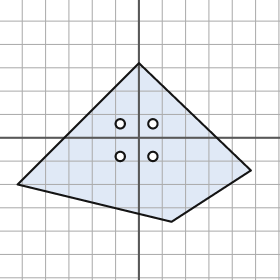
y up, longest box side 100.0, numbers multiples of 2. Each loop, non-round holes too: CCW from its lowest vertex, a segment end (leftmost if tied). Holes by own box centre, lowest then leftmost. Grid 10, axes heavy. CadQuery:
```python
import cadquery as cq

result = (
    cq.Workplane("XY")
    .moveTo(14.0, -36.0)
    .lineTo(48.0, -14.0)
    .lineTo(0.0, 32.0)
    .lineTo(-52.0, -20.0)
    .close()
    .moveTo(-8.0, -8.0)
    .circle(2.0)
    .moveTo(6.0, -8.0)
    .circle(2.0)
    .moveTo(-8.0, 6.0)
    .circle(2.0)
    .moveTo(6.0, 6.0)
    .circle(2.0)
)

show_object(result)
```